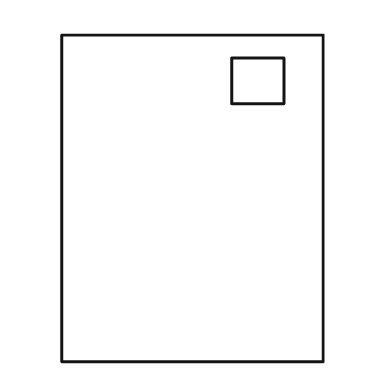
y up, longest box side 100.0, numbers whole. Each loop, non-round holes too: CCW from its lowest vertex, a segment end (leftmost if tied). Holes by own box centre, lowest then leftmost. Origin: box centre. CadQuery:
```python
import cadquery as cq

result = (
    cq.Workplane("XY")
    .moveTo(-40.0, -50.0)
    .lineTo(40.0, -50.0)
    .lineTo(40.0, 50.0)
    .lineTo(-40.0, 50.0)
    .close()
    .moveTo(12.0, 29.0)
    .lineTo(28.0, 29.0)
    .lineTo(28.0, 43.0)
    .lineTo(12.0, 43.0)
    .close()
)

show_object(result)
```